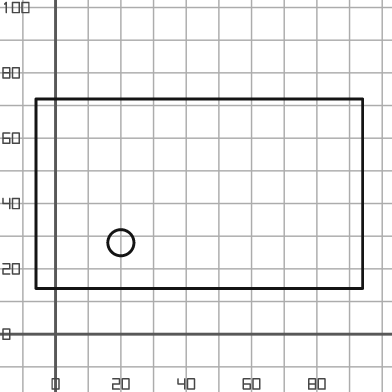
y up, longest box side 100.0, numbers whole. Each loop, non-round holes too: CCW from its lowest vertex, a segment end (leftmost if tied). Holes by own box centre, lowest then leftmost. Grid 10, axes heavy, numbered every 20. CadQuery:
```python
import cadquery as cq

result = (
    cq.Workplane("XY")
    .moveTo(-6.0, 14.0)
    .lineTo(94.0, 14.0)
    .lineTo(94.0, 72.0)
    .lineTo(-6.0, 72.0)
    .close()
    .moveTo(20.0, 28.0)
    .circle(4.0)
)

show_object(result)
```